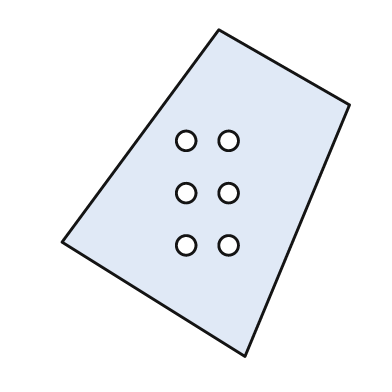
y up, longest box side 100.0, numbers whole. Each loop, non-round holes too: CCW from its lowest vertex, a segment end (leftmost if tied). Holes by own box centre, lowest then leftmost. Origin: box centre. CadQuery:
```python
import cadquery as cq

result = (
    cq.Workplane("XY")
    .moveTo(12.0, -50.0)
    .lineTo(44.0, 27.0)
    .lineTo(4.0, 50.0)
    .lineTo(-44.0, -15.0)
    .close()
    .moveTo(-6.0, -16.0)
    .circle(3.0)
    .moveTo(7.0, -16.0)
    .circle(3.0)
    .moveTo(-6.0, 0.0)
    .circle(3.0)
    .moveTo(7.0, 0.0)
    .circle(3.0)
    .moveTo(-6.0, 16.0)
    .circle(3.0)
    .moveTo(7.0, 16.0)
    .circle(3.0)
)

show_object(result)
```